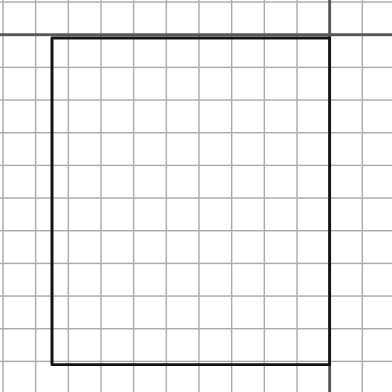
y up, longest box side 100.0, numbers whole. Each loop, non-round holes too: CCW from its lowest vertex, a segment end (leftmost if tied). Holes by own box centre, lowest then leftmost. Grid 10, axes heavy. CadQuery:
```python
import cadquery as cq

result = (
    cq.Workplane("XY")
    .moveTo(-85.0, -101.0)
    .lineTo(0.0, -101.0)
    .lineTo(0.0, -1.0)
    .lineTo(-85.0, -1.0)
    .close()
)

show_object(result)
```